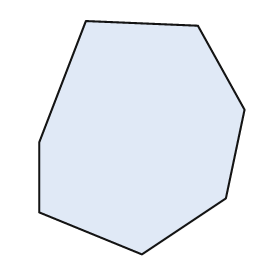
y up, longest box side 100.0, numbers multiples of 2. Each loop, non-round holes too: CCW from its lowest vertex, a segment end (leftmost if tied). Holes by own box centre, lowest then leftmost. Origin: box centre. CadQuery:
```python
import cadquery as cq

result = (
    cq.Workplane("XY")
    .moveTo(0.0, -50.0)
    .lineTo(36.0, -26.0)
    .lineTo(44.0, 12.0)
    .lineTo(24.0, 48.0)
    .lineTo(-24.0, 50.0)
    .lineTo(-44.0, -2.0)
    .lineTo(-44.0, -32.0)
    .close()
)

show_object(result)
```